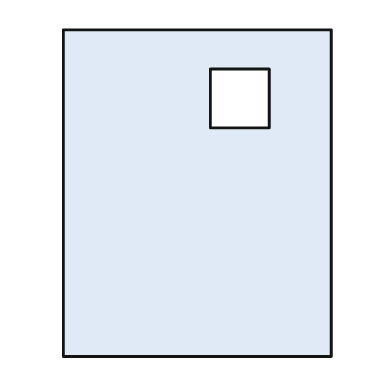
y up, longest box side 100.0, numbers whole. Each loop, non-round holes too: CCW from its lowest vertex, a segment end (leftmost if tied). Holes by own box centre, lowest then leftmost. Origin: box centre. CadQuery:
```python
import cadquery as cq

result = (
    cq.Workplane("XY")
    .moveTo(-41.0, -50.0)
    .lineTo(41.0, -50.0)
    .lineTo(41.0, 50.0)
    .lineTo(-41.0, 50.0)
    .close()
    .moveTo(4.0, 20.0)
    .lineTo(22.0, 20.0)
    .lineTo(22.0, 38.0)
    .lineTo(4.0, 38.0)
    .close()
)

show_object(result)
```